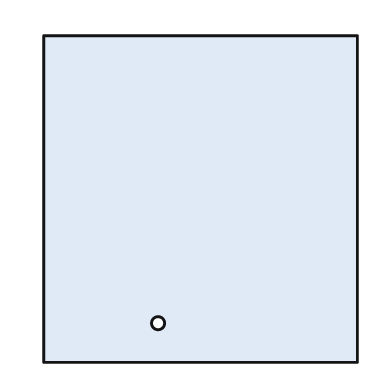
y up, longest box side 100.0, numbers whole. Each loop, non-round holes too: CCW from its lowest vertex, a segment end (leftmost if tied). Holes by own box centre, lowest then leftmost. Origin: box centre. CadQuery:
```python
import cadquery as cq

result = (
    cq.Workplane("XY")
    .moveTo(-48.0, -50.0)
    .lineTo(48.0, -50.0)
    .lineTo(48.0, 50.0)
    .lineTo(-48.0, 50.0)
    .close()
    .moveTo(-13.0, -38.0)
    .circle(2.0)
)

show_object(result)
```